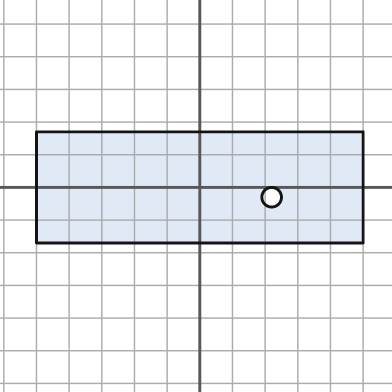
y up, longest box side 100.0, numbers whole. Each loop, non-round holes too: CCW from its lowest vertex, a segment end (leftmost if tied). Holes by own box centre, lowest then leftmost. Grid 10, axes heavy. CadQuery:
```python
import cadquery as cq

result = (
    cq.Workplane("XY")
    .moveTo(-50.0, -17.0)
    .lineTo(50.0, -17.0)
    .lineTo(50.0, 17.0)
    .lineTo(-50.0, 17.0)
    .close()
    .moveTo(22.0, -3.0)
    .circle(3.0)
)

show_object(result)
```